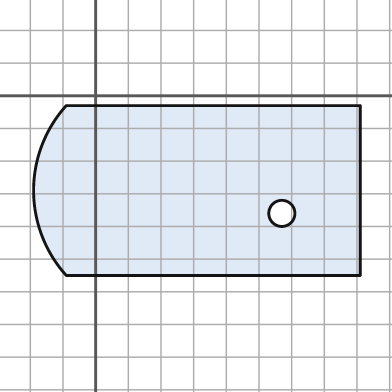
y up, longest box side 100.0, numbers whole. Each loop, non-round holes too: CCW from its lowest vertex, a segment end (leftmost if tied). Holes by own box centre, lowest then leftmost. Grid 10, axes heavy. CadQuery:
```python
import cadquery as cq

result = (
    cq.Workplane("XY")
    .moveTo(-9.0, -55.0)
    .lineTo(81.0, -55.0)
    .lineTo(81.0, -3.0)
    .lineTo(-9.0, -3.0)
    .threePointArc((-19.0, -29.0), (-9.0, -55.0))
    .close()
    .moveTo(57.0, -36.0)
    .circle(4.0)
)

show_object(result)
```